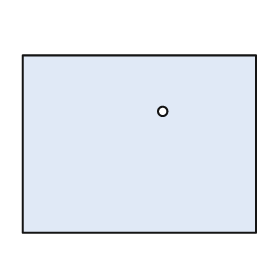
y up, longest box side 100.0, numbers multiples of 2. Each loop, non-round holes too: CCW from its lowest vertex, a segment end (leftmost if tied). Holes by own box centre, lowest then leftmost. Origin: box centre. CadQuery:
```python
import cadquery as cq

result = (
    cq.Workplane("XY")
    .moveTo(-50.0, -38.0)
    .lineTo(50.0, -38.0)
    .lineTo(50.0, 38.0)
    .lineTo(-50.0, 38.0)
    .close()
    .moveTo(10.0, 14.0)
    .circle(2.0)
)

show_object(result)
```